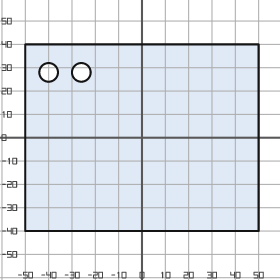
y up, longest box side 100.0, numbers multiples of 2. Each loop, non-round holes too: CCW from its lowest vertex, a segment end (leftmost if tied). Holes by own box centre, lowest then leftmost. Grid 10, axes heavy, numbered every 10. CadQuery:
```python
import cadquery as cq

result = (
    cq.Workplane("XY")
    .moveTo(-50.0, -40.0)
    .lineTo(50.0, -40.0)
    .lineTo(50.0, 40.0)
    .lineTo(-50.0, 40.0)
    .close()
    .moveTo(-40.0, 28.0)
    .circle(4.0)
    .moveTo(-26.0, 28.0)
    .circle(4.0)
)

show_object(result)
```